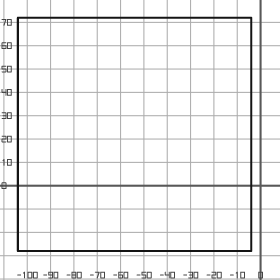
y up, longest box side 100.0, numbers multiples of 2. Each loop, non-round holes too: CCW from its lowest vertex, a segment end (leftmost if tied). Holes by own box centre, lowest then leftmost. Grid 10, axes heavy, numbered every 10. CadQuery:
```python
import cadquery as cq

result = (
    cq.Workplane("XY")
    .moveTo(-104.0, -28.0)
    .lineTo(-4.0, -28.0)
    .lineTo(-4.0, 72.0)
    .lineTo(-104.0, 72.0)
    .close()
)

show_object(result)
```